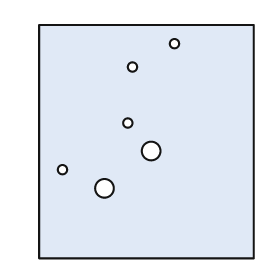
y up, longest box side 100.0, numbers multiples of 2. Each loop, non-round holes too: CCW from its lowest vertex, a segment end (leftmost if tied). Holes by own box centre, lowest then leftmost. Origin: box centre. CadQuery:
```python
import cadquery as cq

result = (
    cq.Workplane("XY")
    .moveTo(-46.0, -50.0)
    .lineTo(46.0, -50.0)
    .lineTo(46.0, 50.0)
    .lineTo(-46.0, 50.0)
    .close()
    .moveTo(-18.0, -20.0)
    .circle(4.0)
    .moveTo(-36.0, -12.0)
    .circle(2.0)
    .moveTo(2.0, -4.0)
    .circle(4.0)
    .moveTo(-8.0, 8.0)
    .circle(2.0)
    .moveTo(-6.0, 32.0)
    .circle(2.0)
    .moveTo(12.0, 42.0)
    .circle(2.0)
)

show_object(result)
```